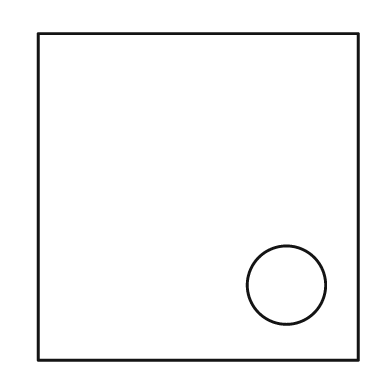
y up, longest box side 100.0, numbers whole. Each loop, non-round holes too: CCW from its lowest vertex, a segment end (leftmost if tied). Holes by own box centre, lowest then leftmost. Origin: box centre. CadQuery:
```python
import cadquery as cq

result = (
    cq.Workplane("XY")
    .moveTo(-49.0, -50.0)
    .lineTo(49.0, -50.0)
    .lineTo(49.0, 50.0)
    .lineTo(-49.0, 50.0)
    .close()
    .moveTo(27.0, -27.0)
    .circle(12.0)
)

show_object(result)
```